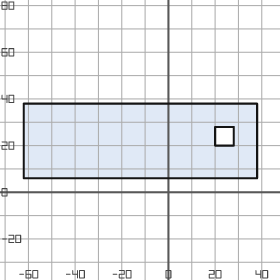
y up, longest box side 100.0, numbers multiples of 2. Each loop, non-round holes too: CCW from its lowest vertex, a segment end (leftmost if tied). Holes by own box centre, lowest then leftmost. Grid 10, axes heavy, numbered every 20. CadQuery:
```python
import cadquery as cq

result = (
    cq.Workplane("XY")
    .moveTo(-62.0, 6.0)
    .lineTo(38.0, 6.0)
    .lineTo(38.0, 38.0)
    .lineTo(-62.0, 38.0)
    .close()
    .moveTo(20.0, 20.0)
    .lineTo(28.0, 20.0)
    .lineTo(28.0, 28.0)
    .lineTo(20.0, 28.0)
    .close()
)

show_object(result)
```